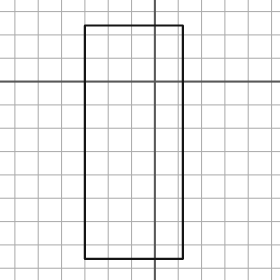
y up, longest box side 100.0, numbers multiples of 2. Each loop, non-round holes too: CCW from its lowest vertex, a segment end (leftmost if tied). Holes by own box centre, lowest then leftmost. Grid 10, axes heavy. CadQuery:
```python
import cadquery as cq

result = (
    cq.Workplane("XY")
    .moveTo(-30.0, -76.0)
    .lineTo(12.0, -76.0)
    .lineTo(12.0, 24.0)
    .lineTo(-30.0, 24.0)
    .close()
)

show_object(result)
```